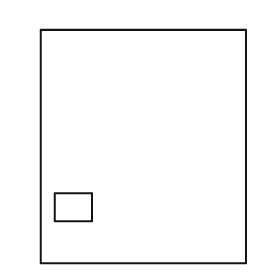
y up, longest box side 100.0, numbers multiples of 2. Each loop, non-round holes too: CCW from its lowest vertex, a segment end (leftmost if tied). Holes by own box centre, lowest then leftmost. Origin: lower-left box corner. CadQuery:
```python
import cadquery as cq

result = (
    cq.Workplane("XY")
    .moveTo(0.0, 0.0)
    .lineTo(88.0, 0.0)
    .lineTo(88.0, 100.0)
    .lineTo(0.0, 100.0)
    .close()
    .moveTo(6.0, 18.0)
    .lineTo(22.0, 18.0)
    .lineTo(22.0, 30.0)
    .lineTo(6.0, 30.0)
    .close()
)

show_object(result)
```